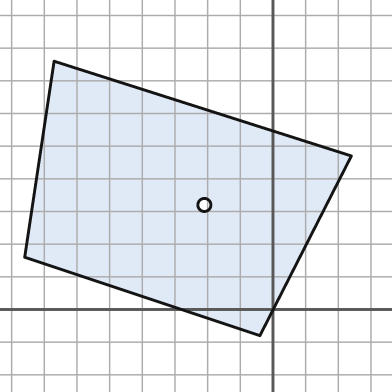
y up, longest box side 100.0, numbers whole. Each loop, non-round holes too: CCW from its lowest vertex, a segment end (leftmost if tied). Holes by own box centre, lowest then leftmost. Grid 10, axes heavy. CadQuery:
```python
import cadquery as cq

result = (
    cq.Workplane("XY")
    .moveTo(-4.0, -8.0)
    .lineTo(24.0, 47.0)
    .lineTo(-67.0, 76.0)
    .lineTo(-76.0, 16.0)
    .close()
    .moveTo(-21.0, 32.0)
    .circle(2.0)
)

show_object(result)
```